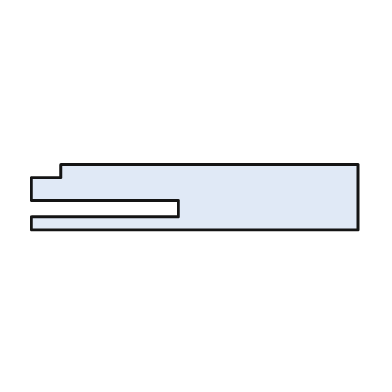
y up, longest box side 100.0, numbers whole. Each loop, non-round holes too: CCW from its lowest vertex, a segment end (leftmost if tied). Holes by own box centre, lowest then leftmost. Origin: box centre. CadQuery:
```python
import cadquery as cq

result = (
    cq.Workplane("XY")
    .moveTo(-50.0, -10.0)
    .lineTo(50.0, -10.0)
    .lineTo(50.0, 10.0)
    .lineTo(-41.0, 10.0)
    .lineTo(-41.0, 6.0)
    .lineTo(-50.0, 6.0)
    .lineTo(-50.0, -1.0)
    .lineTo(-5.0, -1.0)
    .lineTo(-5.0, -6.0)
    .lineTo(-50.0, -6.0)
    .close()
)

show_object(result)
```